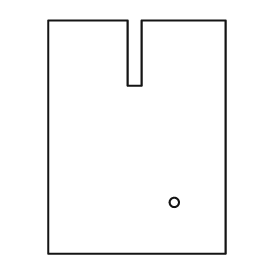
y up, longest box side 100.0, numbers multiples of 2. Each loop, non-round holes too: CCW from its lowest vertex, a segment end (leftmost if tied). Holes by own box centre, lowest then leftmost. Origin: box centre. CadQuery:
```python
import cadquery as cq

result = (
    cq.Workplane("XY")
    .moveTo(-38.0, -50.0)
    .lineTo(38.0, -50.0)
    .lineTo(38.0, 50.0)
    .lineTo(2.0, 50.0)
    .lineTo(2.0, 22.0)
    .lineTo(-4.0, 22.0)
    .lineTo(-4.0, 50.0)
    .lineTo(-38.0, 50.0)
    .close()
    .moveTo(16.0, -28.0)
    .circle(2.0)
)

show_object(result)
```